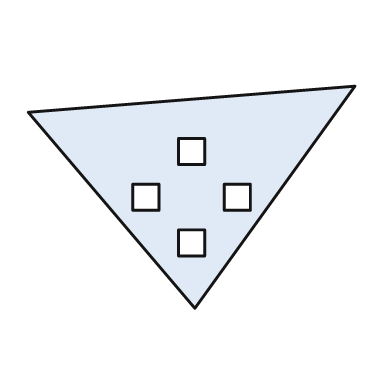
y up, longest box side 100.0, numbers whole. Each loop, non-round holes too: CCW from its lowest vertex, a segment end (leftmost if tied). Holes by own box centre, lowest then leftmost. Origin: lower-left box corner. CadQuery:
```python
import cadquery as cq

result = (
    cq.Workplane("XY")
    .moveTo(51.0, 0.0)
    .lineTo(100.0, 68.0)
    .lineTo(0.0, 60.0)
    .close()
    .moveTo(46.0, 16.0)
    .lineTo(54.0, 16.0)
    .lineTo(54.0, 24.0)
    .lineTo(46.0, 24.0)
    .close()
    .moveTo(32.0, 30.0)
    .lineTo(40.0, 30.0)
    .lineTo(40.0, 38.0)
    .lineTo(32.0, 38.0)
    .close()
    .moveTo(60.0, 30.0)
    .lineTo(68.0, 30.0)
    .lineTo(68.0, 38.0)
    .lineTo(60.0, 38.0)
    .close()
    .moveTo(46.0, 44.0)
    .lineTo(54.0, 44.0)
    .lineTo(54.0, 52.0)
    .lineTo(46.0, 52.0)
    .close()
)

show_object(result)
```